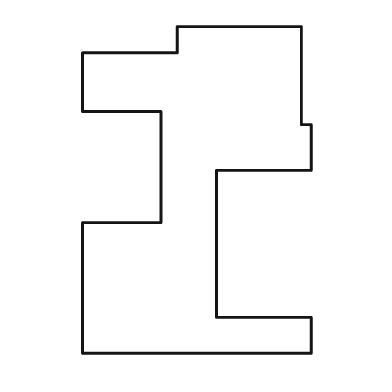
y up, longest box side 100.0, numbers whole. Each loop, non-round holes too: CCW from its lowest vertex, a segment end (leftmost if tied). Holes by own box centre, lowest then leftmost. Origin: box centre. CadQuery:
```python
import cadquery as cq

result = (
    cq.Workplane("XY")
    .moveTo(-35.0, -50.0)
    .lineTo(35.0, -50.0)
    .lineTo(35.0, -39.0)
    .lineTo(6.0, -39.0)
    .lineTo(6.0, 6.0)
    .lineTo(35.0, 6.0)
    .lineTo(35.0, 20.0)
    .lineTo(32.0, 20.0)
    .lineTo(32.0, 50.0)
    .lineTo(-6.0, 50.0)
    .lineTo(-6.0, 42.0)
    .lineTo(-35.0, 42.0)
    .lineTo(-35.0, 24.0)
    .lineTo(-11.0, 24.0)
    .lineTo(-11.0, -10.0)
    .lineTo(-35.0, -10.0)
    .close()
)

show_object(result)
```